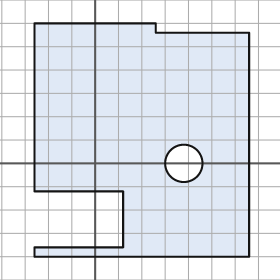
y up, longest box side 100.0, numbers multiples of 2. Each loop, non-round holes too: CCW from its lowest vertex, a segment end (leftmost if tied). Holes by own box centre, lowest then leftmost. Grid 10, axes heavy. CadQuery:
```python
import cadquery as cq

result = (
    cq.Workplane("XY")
    .moveTo(-26.0, -40.0)
    .lineTo(66.0, -40.0)
    .lineTo(66.0, 56.0)
    .lineTo(26.0, 56.0)
    .lineTo(26.0, 60.0)
    .lineTo(-26.0, 60.0)
    .lineTo(-26.0, -12.0)
    .lineTo(12.0, -12.0)
    .lineTo(12.0, -36.0)
    .lineTo(-26.0, -36.0)
    .close()
    .moveTo(38.0, 0.0)
    .circle(8.0)
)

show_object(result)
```